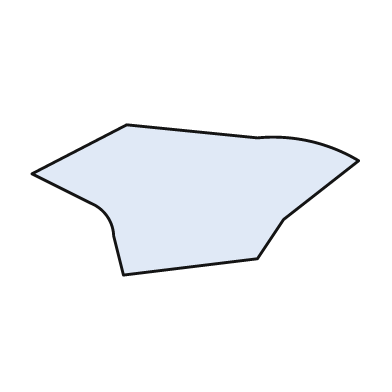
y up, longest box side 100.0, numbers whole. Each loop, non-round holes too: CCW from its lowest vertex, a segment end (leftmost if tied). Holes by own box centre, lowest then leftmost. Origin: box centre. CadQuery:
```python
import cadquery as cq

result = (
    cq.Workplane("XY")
    .moveTo(-22.0, -23.0)
    .lineTo(19.0, -18.0)
    .lineTo(27.0, -6.0)
    .lineTo(50.0, 12.0)
    .threePointArc((35.0, 18.0), (19.0, 19.0))
    .lineTo(-21.0, 23.0)
    .lineTo(-50.0, 8.0)
    .lineTo(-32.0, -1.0)
    .threePointArc((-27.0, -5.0), (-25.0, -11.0))
    .close()
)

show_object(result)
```